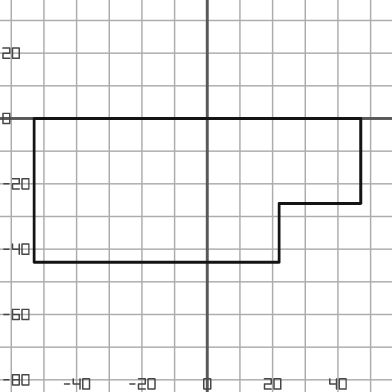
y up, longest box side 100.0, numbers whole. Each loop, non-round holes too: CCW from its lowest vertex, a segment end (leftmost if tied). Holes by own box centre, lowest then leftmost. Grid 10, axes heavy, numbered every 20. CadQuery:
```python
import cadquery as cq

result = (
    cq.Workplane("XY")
    .moveTo(-53.0, -44.0)
    .lineTo(22.0, -44.0)
    .lineTo(22.0, -26.0)
    .lineTo(47.0, -26.0)
    .lineTo(47.0, 0.0)
    .lineTo(-53.0, 0.0)
    .close()
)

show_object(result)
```